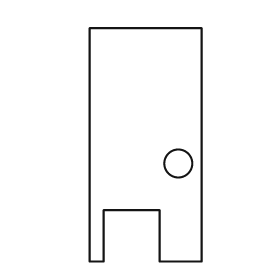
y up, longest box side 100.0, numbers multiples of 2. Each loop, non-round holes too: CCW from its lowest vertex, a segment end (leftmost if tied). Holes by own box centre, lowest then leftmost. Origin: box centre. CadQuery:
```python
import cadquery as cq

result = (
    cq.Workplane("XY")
    .moveTo(-24.0, -50.0)
    .lineTo(-18.0, -50.0)
    .lineTo(-18.0, -28.0)
    .lineTo(6.0, -28.0)
    .lineTo(6.0, -50.0)
    .lineTo(24.0, -50.0)
    .lineTo(24.0, 50.0)
    .lineTo(-24.0, 50.0)
    .close()
    .moveTo(14.0, -8.0)
    .circle(6.0)
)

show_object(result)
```